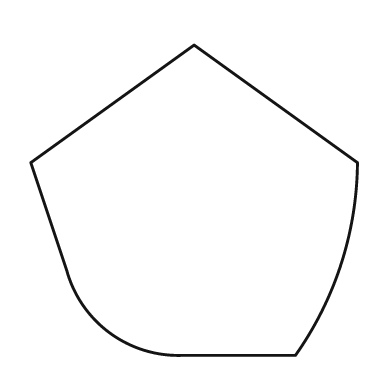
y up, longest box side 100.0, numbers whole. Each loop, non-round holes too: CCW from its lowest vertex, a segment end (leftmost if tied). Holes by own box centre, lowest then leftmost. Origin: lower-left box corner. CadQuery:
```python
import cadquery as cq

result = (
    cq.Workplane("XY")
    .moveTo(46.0, 0.0)
    .lineTo(81.0, 0.0)
    .threePointArc((95.0, 28.0), (100.0, 59.0))
    .lineTo(50.0, 95.0)
    .lineTo(0.0, 59.0)
    .lineTo(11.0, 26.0)
    .threePointArc((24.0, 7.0), (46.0, 0.0))
    .close()
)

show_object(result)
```